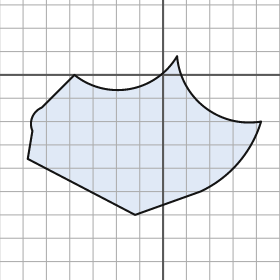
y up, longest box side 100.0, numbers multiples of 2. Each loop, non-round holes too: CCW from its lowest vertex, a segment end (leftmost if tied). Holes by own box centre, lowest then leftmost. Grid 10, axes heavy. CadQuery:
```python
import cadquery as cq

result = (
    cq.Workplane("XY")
    .moveTo(-12.0, -60.0)
    .lineTo(16.0, -50.0)
    .threePointArc((32.0, -38.0), (42.0, -20.0))
    .threePointArc((18.0, -14.0), (6.0, 8.0))
    .threePointArc((-14.0, -6.0), (-38.0, 0.0))
    .lineTo(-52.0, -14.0)
    .threePointArc((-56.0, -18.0), (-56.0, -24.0))
    .lineTo(-58.0, -36.0)
    .close()
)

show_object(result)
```